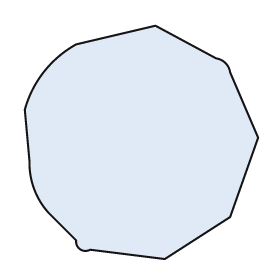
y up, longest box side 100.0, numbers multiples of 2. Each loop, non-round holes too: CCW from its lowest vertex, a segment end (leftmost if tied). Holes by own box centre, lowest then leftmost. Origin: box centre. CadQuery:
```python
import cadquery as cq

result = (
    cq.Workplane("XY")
    .moveTo(10.0, -50.0)
    .lineTo(38.0, -32.0)
    .lineTo(50.0, 2.0)
    .lineTo(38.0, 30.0)
    .threePointArc((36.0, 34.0), (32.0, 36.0))
    .lineTo(6.0, 50.0)
    .lineTo(-28.0, 42.0)
    .threePointArc((-42.0, 30.0), (-50.0, 14.0))
    .lineTo(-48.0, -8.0)
    .threePointArc((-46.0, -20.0), (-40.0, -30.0))
    .lineTo(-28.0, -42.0)
    .threePointArc((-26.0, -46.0), (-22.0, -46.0))
    .close()
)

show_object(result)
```